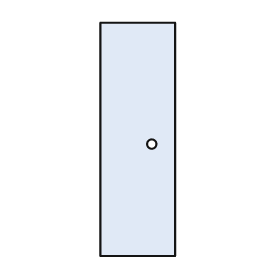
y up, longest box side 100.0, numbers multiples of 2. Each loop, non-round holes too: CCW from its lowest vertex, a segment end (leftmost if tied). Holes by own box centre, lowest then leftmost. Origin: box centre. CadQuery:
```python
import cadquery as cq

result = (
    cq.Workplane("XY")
    .moveTo(-16.0, -50.0)
    .lineTo(16.0, -50.0)
    .lineTo(16.0, 50.0)
    .lineTo(-16.0, 50.0)
    .close()
    .moveTo(6.0, -2.0)
    .circle(2.0)
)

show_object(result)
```